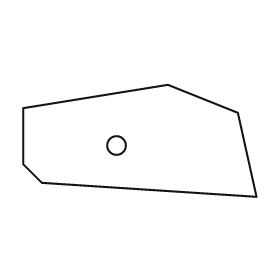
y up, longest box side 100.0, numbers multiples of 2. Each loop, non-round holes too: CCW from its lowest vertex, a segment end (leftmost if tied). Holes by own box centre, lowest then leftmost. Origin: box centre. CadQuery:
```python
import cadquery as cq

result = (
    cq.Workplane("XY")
    .moveTo(50.0, -24.0)
    .lineTo(42.0, 12.0)
    .lineTo(12.0, 24.0)
    .lineTo(-50.0, 14.0)
    .lineTo(-50.0, -10.0)
    .lineTo(-42.0, -18.0)
    .close()
    .moveTo(-10.0, -2.0)
    .circle(4.0)
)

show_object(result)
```